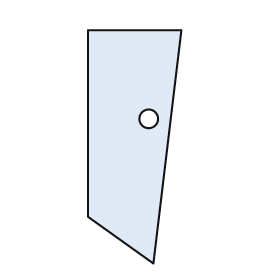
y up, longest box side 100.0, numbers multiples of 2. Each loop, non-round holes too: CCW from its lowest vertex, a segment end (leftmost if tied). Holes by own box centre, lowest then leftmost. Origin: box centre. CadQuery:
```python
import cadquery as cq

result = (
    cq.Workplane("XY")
    .moveTo(8.0, -50.0)
    .lineTo(20.0, 50.0)
    .lineTo(-20.0, 50.0)
    .lineTo(-20.0, -30.0)
    .close()
    .moveTo(6.0, 12.0)
    .circle(4.0)
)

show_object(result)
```